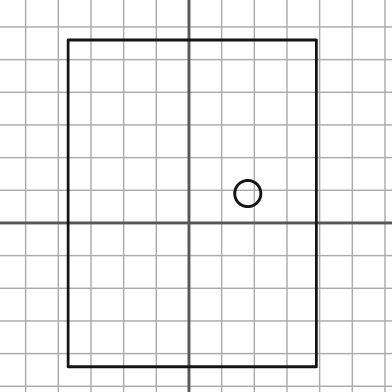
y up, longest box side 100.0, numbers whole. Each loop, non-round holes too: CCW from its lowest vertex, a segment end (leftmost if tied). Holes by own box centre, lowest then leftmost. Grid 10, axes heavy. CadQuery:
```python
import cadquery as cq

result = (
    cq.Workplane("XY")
    .moveTo(-37.0, -44.0)
    .lineTo(39.0, -44.0)
    .lineTo(39.0, 56.0)
    .lineTo(-37.0, 56.0)
    .close()
    .moveTo(18.0, 9.0)
    .circle(4.0)
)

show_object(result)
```